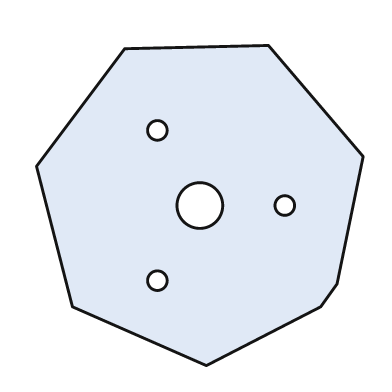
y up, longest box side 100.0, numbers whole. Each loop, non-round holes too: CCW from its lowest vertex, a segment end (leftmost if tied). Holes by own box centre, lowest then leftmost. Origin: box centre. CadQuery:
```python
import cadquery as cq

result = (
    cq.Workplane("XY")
    .moveTo(2.0, -49.0)
    .lineTo(37.0, -31.0)
    .lineTo(42.0, -24.0)
    .lineTo(50.0, 15.0)
    .lineTo(21.0, 49.0)
    .lineTo(-23.0, 48.0)
    .lineTo(-50.0, 12.0)
    .lineTo(-39.0, -31.0)
    .close()
    .moveTo(-13.0, -23.0)
    .circle(3.0)
    .moveTo(0.0, 0.0)
    .circle(7.0)
    .moveTo(26.0, 0.0)
    .circle(3.0)
    .moveTo(-13.0, 23.0)
    .circle(3.0)
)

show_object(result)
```